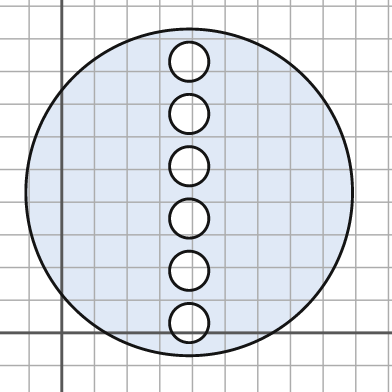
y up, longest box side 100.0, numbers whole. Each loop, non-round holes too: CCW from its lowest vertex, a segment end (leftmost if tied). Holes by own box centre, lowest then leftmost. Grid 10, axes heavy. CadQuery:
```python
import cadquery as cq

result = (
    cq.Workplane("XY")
    .moveTo(39.0, 43.0)
    .circle(50.0)
    .moveTo(39.0, 3.0)
    .circle(6.0)
    .moveTo(39.0, 19.0)
    .circle(6.0)
    .moveTo(39.0, 35.0)
    .circle(6.0)
    .moveTo(39.0, 51.0)
    .circle(6.0)
    .moveTo(39.0, 67.0)
    .circle(6.0)
    .moveTo(39.0, 83.0)
    .circle(6.0)
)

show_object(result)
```